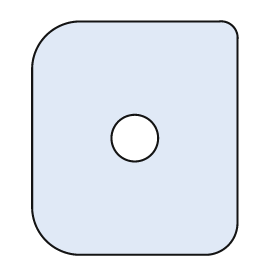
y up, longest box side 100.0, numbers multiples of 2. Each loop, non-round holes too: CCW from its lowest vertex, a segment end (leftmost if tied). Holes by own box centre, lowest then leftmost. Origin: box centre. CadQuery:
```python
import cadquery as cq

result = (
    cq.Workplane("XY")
    .moveTo(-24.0, -50.0)
    .lineTo(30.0, -50.0)
    .threePointArc((40.0, -46.0), (44.0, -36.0))
    .lineTo(44.0, 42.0)
    .threePointArc((42.0, 48.0), (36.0, 50.0))
    .lineTo(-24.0, 50.0)
    .threePointArc((-38.0, 44.0), (-44.0, 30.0))
    .lineTo(-44.0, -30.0)
    .threePointArc((-38.0, -44.0), (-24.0, -50.0))
    .close()
    .moveTo(0.0, 0.0)
    .circle(10.0)
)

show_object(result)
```